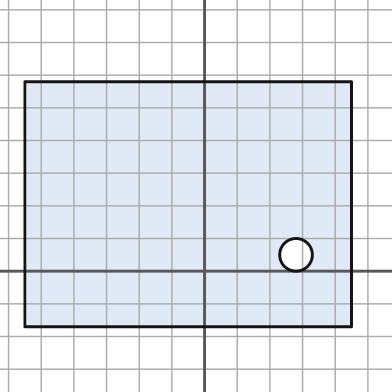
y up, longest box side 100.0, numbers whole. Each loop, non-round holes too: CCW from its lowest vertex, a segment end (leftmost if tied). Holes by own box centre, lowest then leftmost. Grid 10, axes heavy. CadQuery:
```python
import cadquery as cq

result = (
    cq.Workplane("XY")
    .moveTo(-55.0, -17.0)
    .lineTo(45.0, -17.0)
    .lineTo(45.0, 58.0)
    .lineTo(-55.0, 58.0)
    .close()
    .moveTo(28.0, 5.0)
    .circle(5.0)
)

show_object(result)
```